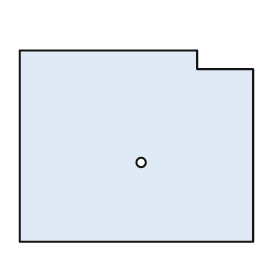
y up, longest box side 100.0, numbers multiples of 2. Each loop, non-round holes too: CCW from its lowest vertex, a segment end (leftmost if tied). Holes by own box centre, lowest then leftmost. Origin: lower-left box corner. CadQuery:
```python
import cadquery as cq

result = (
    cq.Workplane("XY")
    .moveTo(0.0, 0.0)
    .lineTo(100.0, 0.0)
    .lineTo(100.0, 74.0)
    .lineTo(76.0, 74.0)
    .lineTo(76.0, 82.0)
    .lineTo(0.0, 82.0)
    .close()
    .moveTo(52.0, 34.0)
    .circle(2.0)
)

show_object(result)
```